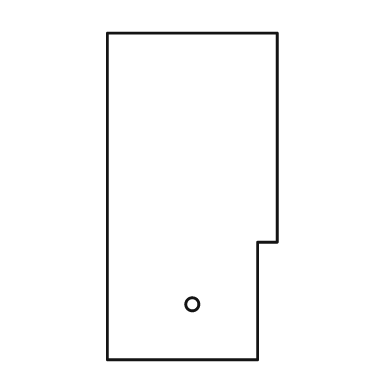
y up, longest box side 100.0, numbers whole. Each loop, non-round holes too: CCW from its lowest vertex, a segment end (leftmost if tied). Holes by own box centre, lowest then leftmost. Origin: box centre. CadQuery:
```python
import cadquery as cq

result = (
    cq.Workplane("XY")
    .moveTo(-26.0, -50.0)
    .lineTo(20.0, -50.0)
    .lineTo(20.0, -14.0)
    .lineTo(26.0, -14.0)
    .lineTo(26.0, 50.0)
    .lineTo(-26.0, 50.0)
    .close()
    .moveTo(0.0, -33.0)
    .circle(2.0)
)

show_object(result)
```